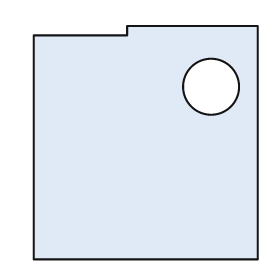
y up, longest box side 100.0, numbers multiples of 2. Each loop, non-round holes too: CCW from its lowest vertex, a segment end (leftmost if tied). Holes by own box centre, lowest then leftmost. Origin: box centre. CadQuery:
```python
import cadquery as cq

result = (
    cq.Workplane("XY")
    .moveTo(-48.0, -50.0)
    .lineTo(48.0, -50.0)
    .lineTo(48.0, 50.0)
    .lineTo(-8.0, 50.0)
    .lineTo(-8.0, 46.0)
    .lineTo(-48.0, 46.0)
    .close()
    .moveTo(28.0, 24.0)
    .circle(12.0)
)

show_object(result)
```